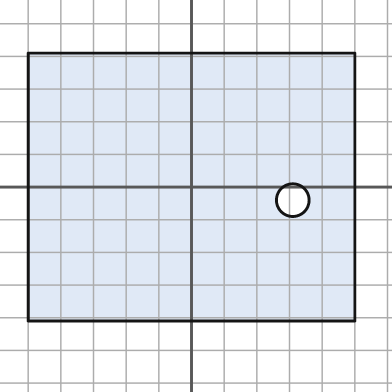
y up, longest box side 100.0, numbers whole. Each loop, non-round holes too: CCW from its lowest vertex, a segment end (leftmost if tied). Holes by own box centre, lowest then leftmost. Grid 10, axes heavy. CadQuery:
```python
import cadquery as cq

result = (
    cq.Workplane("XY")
    .moveTo(-50.0, -41.0)
    .lineTo(50.0, -41.0)
    .lineTo(50.0, 41.0)
    .lineTo(-50.0, 41.0)
    .close()
    .moveTo(31.0, -4.0)
    .circle(5.0)
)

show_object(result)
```